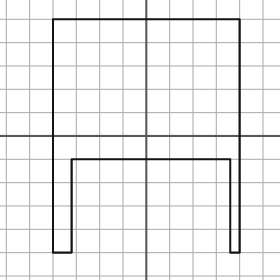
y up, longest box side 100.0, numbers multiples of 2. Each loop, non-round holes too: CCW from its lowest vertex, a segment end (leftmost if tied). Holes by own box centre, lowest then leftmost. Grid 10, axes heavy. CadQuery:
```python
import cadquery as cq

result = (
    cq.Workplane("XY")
    .moveTo(-40.0, -50.0)
    .lineTo(-32.0, -50.0)
    .lineTo(-32.0, -10.0)
    .lineTo(36.0, -10.0)
    .lineTo(36.0, -50.0)
    .lineTo(40.0, -50.0)
    .lineTo(40.0, 50.0)
    .lineTo(-40.0, 50.0)
    .close()
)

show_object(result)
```